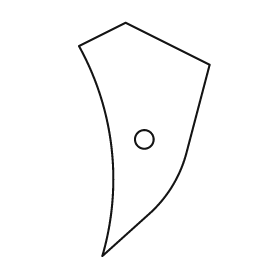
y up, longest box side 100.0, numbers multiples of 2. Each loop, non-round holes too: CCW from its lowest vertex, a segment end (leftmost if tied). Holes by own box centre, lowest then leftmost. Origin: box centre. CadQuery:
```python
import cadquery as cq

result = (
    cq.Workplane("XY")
    .moveTo(-18.0, -50.0)
    .lineTo(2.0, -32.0)
    .threePointArc((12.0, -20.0), (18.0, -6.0))
    .lineTo(28.0, 32.0)
    .lineTo(-8.0, 50.0)
    .lineTo(-28.0, 40.0)
    .threePointArc((-14.0, -4.0), (-18.0, -50.0))
    .close()
    .moveTo(0.0, 0.0)
    .circle(4.0)
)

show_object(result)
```